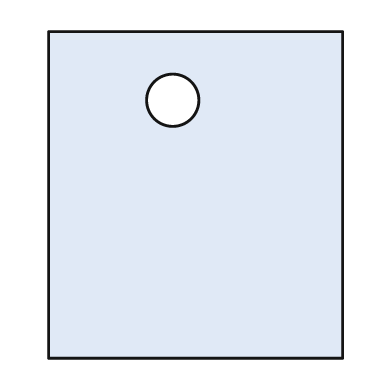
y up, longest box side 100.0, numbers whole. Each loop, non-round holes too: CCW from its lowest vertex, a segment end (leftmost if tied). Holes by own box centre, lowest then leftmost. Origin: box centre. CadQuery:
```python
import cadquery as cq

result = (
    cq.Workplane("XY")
    .moveTo(-45.0, -50.0)
    .lineTo(45.0, -50.0)
    .lineTo(45.0, 50.0)
    .lineTo(-45.0, 50.0)
    .close()
    .moveTo(-7.0, 29.0)
    .circle(8.0)
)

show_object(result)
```